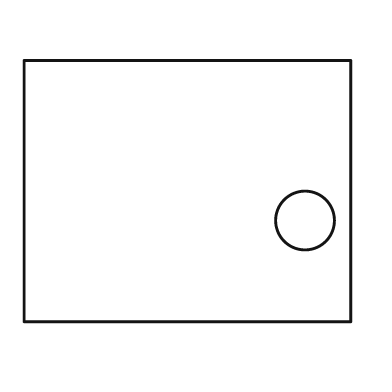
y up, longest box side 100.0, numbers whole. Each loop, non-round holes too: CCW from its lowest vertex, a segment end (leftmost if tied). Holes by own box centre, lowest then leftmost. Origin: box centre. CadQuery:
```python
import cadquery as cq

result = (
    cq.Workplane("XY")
    .moveTo(-50.0, -40.0)
    .lineTo(50.0, -40.0)
    .lineTo(50.0, 40.0)
    .lineTo(-50.0, 40.0)
    .close()
    .moveTo(36.0, -9.0)
    .circle(9.0)
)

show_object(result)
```